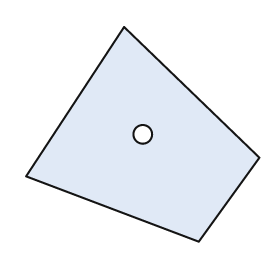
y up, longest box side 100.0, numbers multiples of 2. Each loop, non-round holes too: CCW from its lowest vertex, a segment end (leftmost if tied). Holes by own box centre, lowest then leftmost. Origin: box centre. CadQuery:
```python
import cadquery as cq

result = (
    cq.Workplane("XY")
    .moveTo(24.0, -46.0)
    .lineTo(50.0, -10.0)
    .lineTo(-8.0, 46.0)
    .lineTo(-50.0, -18.0)
    .close()
    .moveTo(0.0, 0.0)
    .circle(4.0)
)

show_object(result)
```